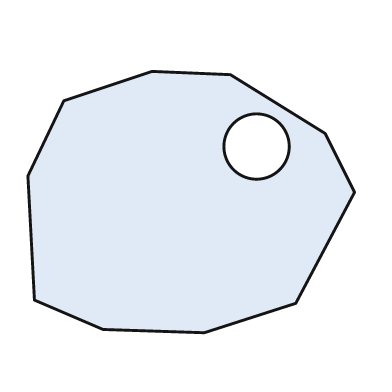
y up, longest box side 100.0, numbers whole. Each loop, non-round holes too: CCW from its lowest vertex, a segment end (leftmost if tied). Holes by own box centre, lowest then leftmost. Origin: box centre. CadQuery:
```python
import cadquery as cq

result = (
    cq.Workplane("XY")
    .moveTo(4.0, -40.0)
    .lineTo(32.0, -31.0)
    .lineTo(50.0, 3.0)
    .lineTo(41.0, 21.0)
    .lineTo(12.0, 39.0)
    .lineTo(-12.0, 40.0)
    .lineTo(-39.0, 31.0)
    .lineTo(-50.0, 8.0)
    .lineTo(-48.0, -30.0)
    .lineTo(-27.0, -39.0)
    .close()
    .moveTo(20.0, 17.0)
    .circle(10.0)
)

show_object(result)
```